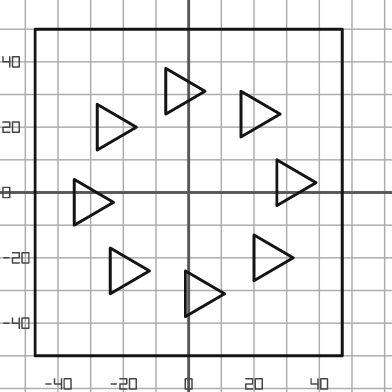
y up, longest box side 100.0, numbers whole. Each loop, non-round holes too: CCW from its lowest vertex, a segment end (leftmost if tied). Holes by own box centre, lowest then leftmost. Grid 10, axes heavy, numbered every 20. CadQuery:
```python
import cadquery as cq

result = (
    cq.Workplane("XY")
    .moveTo(-47.0, -50.0)
    .lineTo(47.0, -50.0)
    .lineTo(47.0, 50.0)
    .lineTo(-47.0, 50.0)
    .close()
    .moveTo(-1.0, -38.0)
    .lineTo(11.0, -31.0)
    .lineTo(-1.0, -24.0)
    .close()
    .moveTo(-24.0, -31.0)
    .lineTo(-12.0, -24.0)
    .lineTo(-24.0, -17.0)
    .close()
    .moveTo(20.0, -27.0)
    .lineTo(32.0, -20.0)
    .lineTo(20.0, -13.0)
    .close()
    .moveTo(-35.0, -10.0)
    .lineTo(-23.0, -3.0)
    .lineTo(-35.0, 4.0)
    .close()
    .moveTo(27.0, -4.0)
    .lineTo(39.0, 3.0)
    .lineTo(27.0, 10.0)
    .close()
    .moveTo(-28.0, 13.0)
    .lineTo(-16.0, 20.0)
    .lineTo(-28.0, 27.0)
    .close()
    .moveTo(16.0, 17.0)
    .lineTo(28.0, 24.0)
    .lineTo(16.0, 31.0)
    .close()
    .moveTo(-7.0, 24.0)
    .lineTo(5.0, 31.0)
    .lineTo(-7.0, 38.0)
    .close()
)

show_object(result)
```